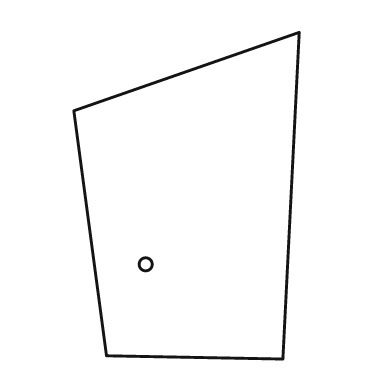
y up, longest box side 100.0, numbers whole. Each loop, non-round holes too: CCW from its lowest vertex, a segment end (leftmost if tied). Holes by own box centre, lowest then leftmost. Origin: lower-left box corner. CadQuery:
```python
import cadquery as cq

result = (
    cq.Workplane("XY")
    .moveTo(64.0, 0.0)
    .lineTo(69.0, 100.0)
    .lineTo(0.0, 76.0)
    .lineTo(10.0, 1.0)
    .close()
    .moveTo(22.0, 29.0)
    .circle(2.0)
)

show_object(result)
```